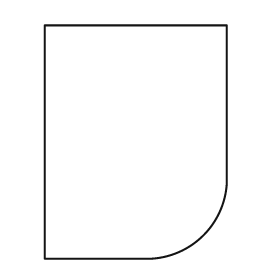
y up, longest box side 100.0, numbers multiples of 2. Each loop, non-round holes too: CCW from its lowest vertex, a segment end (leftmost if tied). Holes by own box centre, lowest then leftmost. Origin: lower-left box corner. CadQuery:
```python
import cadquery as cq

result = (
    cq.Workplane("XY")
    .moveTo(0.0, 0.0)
    .lineTo(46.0, 0.0)
    .threePointArc((68.0, 10.0), (78.0, 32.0))
    .lineTo(78.0, 100.0)
    .lineTo(0.0, 100.0)
    .close()
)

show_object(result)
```